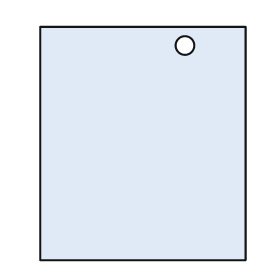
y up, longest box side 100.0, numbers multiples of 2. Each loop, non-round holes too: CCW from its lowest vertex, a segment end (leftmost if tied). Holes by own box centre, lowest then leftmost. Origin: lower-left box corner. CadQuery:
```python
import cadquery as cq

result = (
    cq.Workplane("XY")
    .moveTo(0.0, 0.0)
    .lineTo(88.0, 0.0)
    .lineTo(88.0, 100.0)
    .lineTo(0.0, 100.0)
    .close()
    .moveTo(62.0, 92.0)
    .circle(4.0)
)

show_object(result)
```